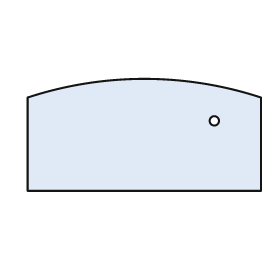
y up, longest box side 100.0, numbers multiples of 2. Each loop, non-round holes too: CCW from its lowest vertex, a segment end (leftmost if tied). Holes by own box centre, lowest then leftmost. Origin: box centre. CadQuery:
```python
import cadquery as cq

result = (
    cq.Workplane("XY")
    .moveTo(-50.0, -24.0)
    .lineTo(50.0, -24.0)
    .lineTo(50.0, 16.0)
    .threePointArc((0.0, 24.0), (-50.0, 16.0))
    .close()
    .moveTo(30.0, 6.0)
    .circle(2.0)
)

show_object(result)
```